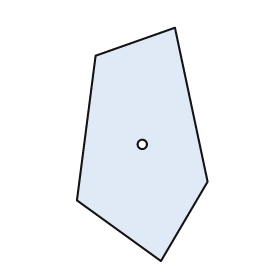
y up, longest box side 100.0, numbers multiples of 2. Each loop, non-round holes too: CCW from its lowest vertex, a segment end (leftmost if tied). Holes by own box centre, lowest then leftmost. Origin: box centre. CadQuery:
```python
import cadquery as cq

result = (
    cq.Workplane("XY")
    .moveTo(8.0, -50.0)
    .lineTo(28.0, -16.0)
    .lineTo(14.0, 50.0)
    .lineTo(-20.0, 38.0)
    .lineTo(-28.0, -24.0)
    .close()
    .moveTo(0.0, 0.0)
    .circle(2.0)
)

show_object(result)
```